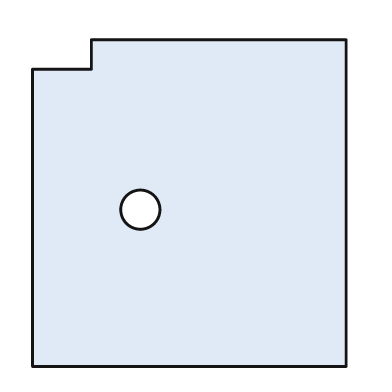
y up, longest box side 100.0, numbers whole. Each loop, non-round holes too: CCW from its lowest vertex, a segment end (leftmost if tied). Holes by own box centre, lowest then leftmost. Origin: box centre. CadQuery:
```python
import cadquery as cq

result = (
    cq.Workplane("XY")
    .moveTo(-48.0, -50.0)
    .lineTo(48.0, -50.0)
    .lineTo(48.0, 50.0)
    .lineTo(-30.0, 50.0)
    .lineTo(-30.0, 41.0)
    .lineTo(-48.0, 41.0)
    .close()
    .moveTo(-15.0, -2.0)
    .circle(6.0)
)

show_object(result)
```